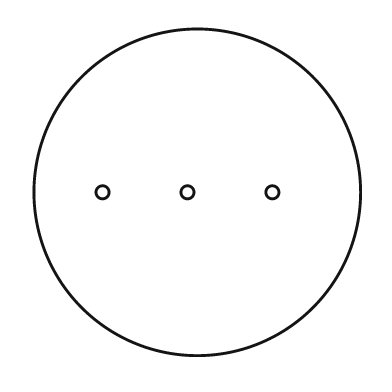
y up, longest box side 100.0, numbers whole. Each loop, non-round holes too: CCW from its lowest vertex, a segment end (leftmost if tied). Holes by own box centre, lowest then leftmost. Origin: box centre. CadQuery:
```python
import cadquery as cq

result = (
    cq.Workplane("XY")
    .moveTo(0.0, 0.0)
    .circle(50.0)
    .moveTo(-29.0, 0.0)
    .circle(2.0)
    .moveTo(-3.0, 0.0)
    .circle(2.0)
    .moveTo(23.0, 0.0)
    .circle(2.0)
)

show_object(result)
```